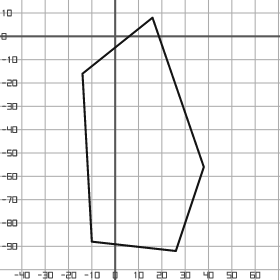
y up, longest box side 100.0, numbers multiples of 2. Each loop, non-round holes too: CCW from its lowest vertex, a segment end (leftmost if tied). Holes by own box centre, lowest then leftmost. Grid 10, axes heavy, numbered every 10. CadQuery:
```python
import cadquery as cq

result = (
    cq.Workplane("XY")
    .moveTo(26.0, -92.0)
    .lineTo(38.0, -56.0)
    .lineTo(16.0, 8.0)
    .lineTo(-14.0, -16.0)
    .lineTo(-10.0, -88.0)
    .close()
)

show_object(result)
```